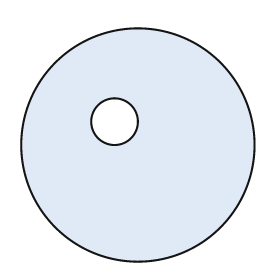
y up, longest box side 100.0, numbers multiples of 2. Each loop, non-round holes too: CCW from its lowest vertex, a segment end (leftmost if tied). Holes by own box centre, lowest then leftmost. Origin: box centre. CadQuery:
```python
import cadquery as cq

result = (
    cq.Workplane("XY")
    .moveTo(0.0, 0.0)
    .circle(50.0)
    .moveTo(-10.0, 10.0)
    .circle(10.0)
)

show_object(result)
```